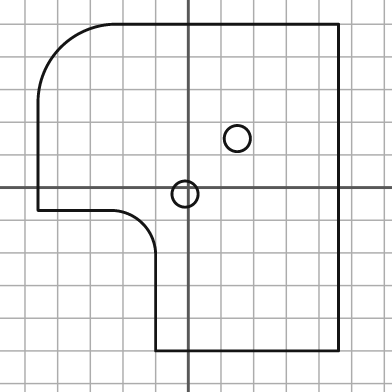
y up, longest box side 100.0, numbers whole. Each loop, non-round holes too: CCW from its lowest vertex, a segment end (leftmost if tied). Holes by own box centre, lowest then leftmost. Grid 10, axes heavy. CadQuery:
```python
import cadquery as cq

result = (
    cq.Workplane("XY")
    .moveTo(-10.0, -50.0)
    .lineTo(46.0, -50.0)
    .lineTo(46.0, 50.0)
    .lineTo(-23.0, 50.0)
    .threePointArc((-39.0, 43.0), (-46.0, 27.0))
    .lineTo(-46.0, -7.0)
    .lineTo(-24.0, -7.0)
    .threePointArc((-14.0, -11.0), (-10.0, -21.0))
    .close()
    .moveTo(-1.0, -2.0)
    .circle(4.0)
    .moveTo(15.0, 15.0)
    .circle(4.0)
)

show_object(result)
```